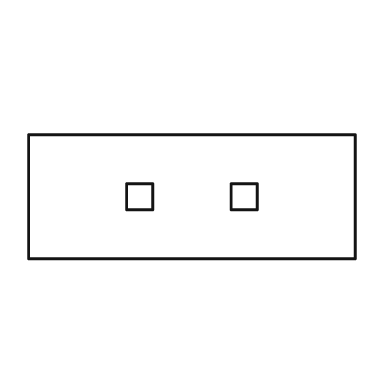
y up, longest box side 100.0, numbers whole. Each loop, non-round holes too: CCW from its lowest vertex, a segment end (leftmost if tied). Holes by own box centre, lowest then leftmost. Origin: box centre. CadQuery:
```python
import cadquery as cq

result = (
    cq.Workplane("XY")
    .moveTo(-50.0, -19.0)
    .lineTo(50.0, -19.0)
    .lineTo(50.0, 19.0)
    .lineTo(-50.0, 19.0)
    .close()
    .moveTo(-20.0, -4.0)
    .lineTo(-12.0, -4.0)
    .lineTo(-12.0, 4.0)
    .lineTo(-20.0, 4.0)
    .close()
    .moveTo(12.0, -4.0)
    .lineTo(20.0, -4.0)
    .lineTo(20.0, 4.0)
    .lineTo(12.0, 4.0)
    .close()
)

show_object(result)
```